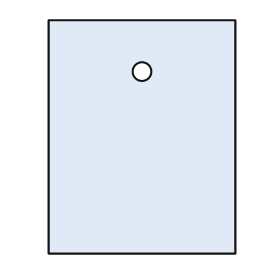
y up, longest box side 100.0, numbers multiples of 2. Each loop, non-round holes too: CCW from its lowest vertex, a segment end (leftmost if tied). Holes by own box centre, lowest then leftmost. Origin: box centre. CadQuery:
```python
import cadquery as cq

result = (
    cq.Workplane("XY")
    .moveTo(-40.0, -50.0)
    .lineTo(40.0, -50.0)
    .lineTo(40.0, 50.0)
    .lineTo(-40.0, 50.0)
    .close()
    .moveTo(0.0, 28.0)
    .circle(4.0)
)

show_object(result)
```